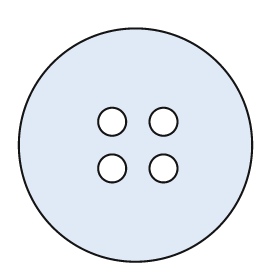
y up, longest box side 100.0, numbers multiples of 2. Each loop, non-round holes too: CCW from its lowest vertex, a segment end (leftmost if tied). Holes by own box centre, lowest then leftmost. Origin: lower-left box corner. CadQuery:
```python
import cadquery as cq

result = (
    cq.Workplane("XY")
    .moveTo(50.0, 50.0)
    .circle(50.0)
    .moveTo(40.0, 40.0)
    .circle(6.0)
    .moveTo(62.0, 40.0)
    .circle(6.0)
    .moveTo(40.0, 60.0)
    .circle(6.0)
    .moveTo(62.0, 60.0)
    .circle(6.0)
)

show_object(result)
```